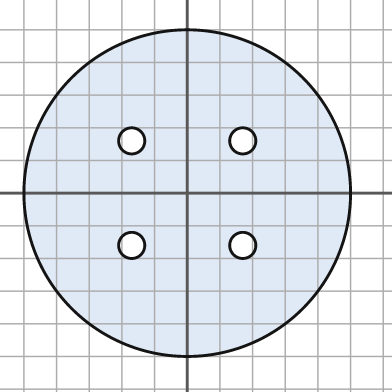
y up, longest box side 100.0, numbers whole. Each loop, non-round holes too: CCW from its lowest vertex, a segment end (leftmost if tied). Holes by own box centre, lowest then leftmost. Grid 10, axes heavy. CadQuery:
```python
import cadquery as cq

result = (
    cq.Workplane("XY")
    .moveTo(0.0, 0.0)
    .circle(50.0)
    .moveTo(-17.0, -16.0)
    .circle(4.0)
    .moveTo(17.0, -16.0)
    .circle(4.0)
    .moveTo(-17.0, 16.0)
    .circle(4.0)
    .moveTo(17.0, 16.0)
    .circle(4.0)
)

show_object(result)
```